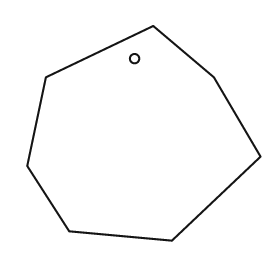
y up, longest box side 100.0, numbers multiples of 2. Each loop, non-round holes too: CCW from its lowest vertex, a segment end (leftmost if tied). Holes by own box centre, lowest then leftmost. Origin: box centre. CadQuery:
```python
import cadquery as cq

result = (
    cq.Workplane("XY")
    .moveTo(12.0, -46.0)
    .lineTo(50.0, -10.0)
    .lineTo(30.0, 24.0)
    .lineTo(4.0, 46.0)
    .lineTo(-42.0, 24.0)
    .lineTo(-50.0, -14.0)
    .lineTo(-32.0, -42.0)
    .close()
    .moveTo(-4.0, 32.0)
    .circle(2.0)
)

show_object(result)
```